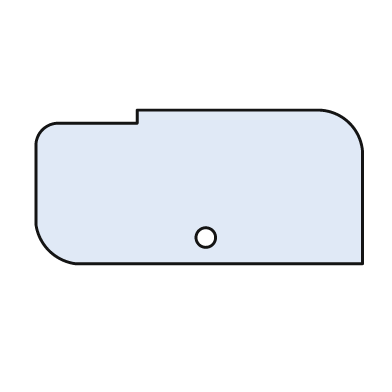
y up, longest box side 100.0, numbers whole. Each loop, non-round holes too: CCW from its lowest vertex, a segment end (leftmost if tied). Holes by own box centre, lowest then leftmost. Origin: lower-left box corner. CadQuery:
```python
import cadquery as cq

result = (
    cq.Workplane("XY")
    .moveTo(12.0, 0.0)
    .lineTo(100.0, 0.0)
    .lineTo(100.0, 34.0)
    .threePointArc((96.0, 43.0), (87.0, 47.0))
    .lineTo(31.0, 47.0)
    .lineTo(31.0, 43.0)
    .lineTo(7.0, 43.0)
    .threePointArc((2.0, 41.0), (0.0, 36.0))
    .lineTo(0.0, 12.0)
    .threePointArc((4.0, 4.0), (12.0, 0.0))
    .close()
    .moveTo(52.0, 8.0)
    .circle(3.0)
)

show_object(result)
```